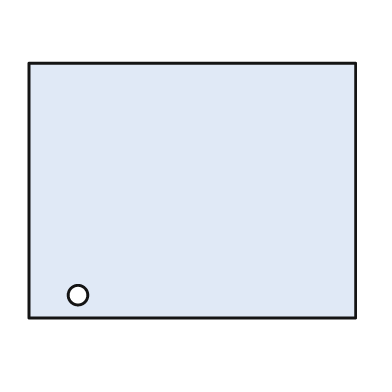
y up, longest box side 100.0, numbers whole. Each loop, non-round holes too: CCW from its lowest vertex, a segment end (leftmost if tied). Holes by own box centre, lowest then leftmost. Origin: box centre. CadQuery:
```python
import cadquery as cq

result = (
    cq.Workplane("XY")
    .moveTo(-50.0, -39.0)
    .lineTo(50.0, -39.0)
    .lineTo(50.0, 39.0)
    .lineTo(-50.0, 39.0)
    .close()
    .moveTo(-35.0, -32.0)
    .circle(3.0)
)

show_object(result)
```